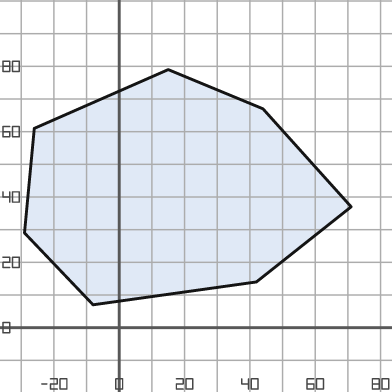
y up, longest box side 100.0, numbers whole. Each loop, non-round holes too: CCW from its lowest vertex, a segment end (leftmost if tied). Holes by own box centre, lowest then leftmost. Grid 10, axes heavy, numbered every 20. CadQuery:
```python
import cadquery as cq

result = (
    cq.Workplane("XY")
    .moveTo(-8.0, 7.0)
    .lineTo(42.0, 14.0)
    .lineTo(71.0, 37.0)
    .lineTo(44.0, 67.0)
    .lineTo(15.0, 79.0)
    .lineTo(-26.0, 61.0)
    .lineTo(-29.0, 29.0)
    .close()
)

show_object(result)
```